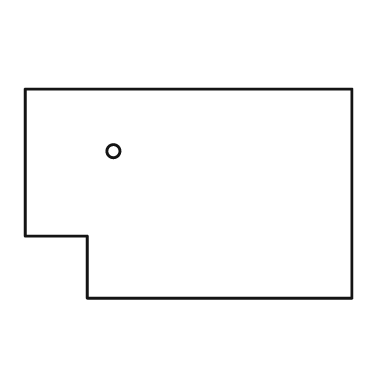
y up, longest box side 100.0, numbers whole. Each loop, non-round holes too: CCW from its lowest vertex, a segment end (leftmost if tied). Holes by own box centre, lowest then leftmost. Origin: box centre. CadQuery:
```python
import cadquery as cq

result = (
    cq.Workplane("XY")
    .moveTo(-31.0, -32.0)
    .lineTo(50.0, -32.0)
    .lineTo(50.0, 32.0)
    .lineTo(-50.0, 32.0)
    .lineTo(-50.0, -13.0)
    .lineTo(-31.0, -13.0)
    .close()
    .moveTo(-23.0, 13.0)
    .circle(2.0)
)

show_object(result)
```